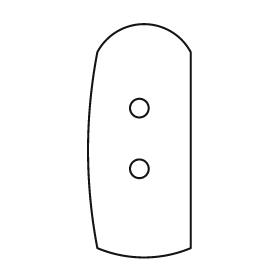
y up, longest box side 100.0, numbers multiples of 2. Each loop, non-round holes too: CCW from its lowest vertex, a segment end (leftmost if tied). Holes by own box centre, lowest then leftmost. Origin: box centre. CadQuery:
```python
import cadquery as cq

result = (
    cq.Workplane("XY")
    .moveTo(-18.0, -46.0)
    .threePointArc((2.0, -50.0), (22.0, -46.0))
    .lineTo(22.0, 38.0)
    .threePointArc((2.0, 50.0), (-18.0, 38.0))
    .threePointArc((-22.0, -4.0), (-18.0, -46.0))
    .close()
    .moveTo(0.0, -12.0)
    .circle(4.0)
    .moveTo(0.0, 14.0)
    .circle(4.0)
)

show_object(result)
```